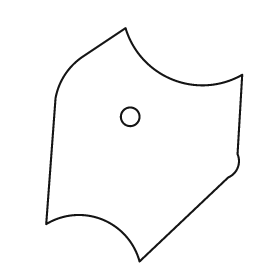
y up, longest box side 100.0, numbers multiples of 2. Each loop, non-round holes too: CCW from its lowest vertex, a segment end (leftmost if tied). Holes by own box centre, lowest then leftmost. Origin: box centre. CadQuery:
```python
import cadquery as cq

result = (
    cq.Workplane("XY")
    .moveTo(-2.0, -50.0)
    .lineTo(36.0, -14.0)
    .threePointArc((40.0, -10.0), (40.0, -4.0))
    .lineTo(42.0, 30.0)
    .threePointArc((12.0, 28.0), (-8.0, 50.0))
    .lineTo(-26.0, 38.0)
    .threePointArc((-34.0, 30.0), (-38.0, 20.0))
    .lineTo(-42.0, -34.0)
    .threePointArc((-18.0, -32.0), (-2.0, -50.0))
    .close()
    .moveTo(-6.0, 12.0)
    .circle(4.0)
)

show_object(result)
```